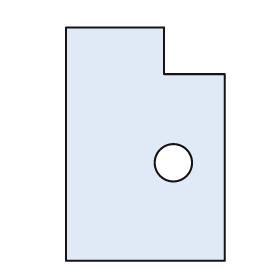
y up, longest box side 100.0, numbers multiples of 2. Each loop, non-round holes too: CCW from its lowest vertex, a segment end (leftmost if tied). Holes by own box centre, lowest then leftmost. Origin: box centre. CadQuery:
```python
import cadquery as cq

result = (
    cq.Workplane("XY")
    .moveTo(-34.0, -50.0)
    .lineTo(34.0, -50.0)
    .lineTo(34.0, 30.0)
    .lineTo(8.0, 30.0)
    .lineTo(8.0, 50.0)
    .lineTo(-34.0, 50.0)
    .close()
    .moveTo(12.0, -8.0)
    .circle(8.0)
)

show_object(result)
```